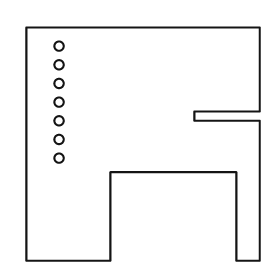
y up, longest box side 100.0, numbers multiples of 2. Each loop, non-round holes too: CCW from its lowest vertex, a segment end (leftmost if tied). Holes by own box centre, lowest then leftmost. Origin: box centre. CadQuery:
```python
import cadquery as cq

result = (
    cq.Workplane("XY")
    .moveTo(-50.0, -50.0)
    .lineTo(-14.0, -50.0)
    .lineTo(-14.0, -12.0)
    .lineTo(40.0, -12.0)
    .lineTo(40.0, -50.0)
    .lineTo(50.0, -50.0)
    .lineTo(50.0, 10.0)
    .lineTo(22.0, 10.0)
    .lineTo(22.0, 14.0)
    .lineTo(50.0, 14.0)
    .lineTo(50.0, 50.0)
    .lineTo(-50.0, 50.0)
    .close()
    .moveTo(-36.0, -6.0)
    .circle(2.0)
    .moveTo(-36.0, 2.0)
    .circle(2.0)
    .moveTo(-36.0, 10.0)
    .circle(2.0)
    .moveTo(-36.0, 18.0)
    .circle(2.0)
    .moveTo(-36.0, 26.0)
    .circle(2.0)
    .moveTo(-36.0, 34.0)
    .circle(2.0)
    .moveTo(-36.0, 42.0)
    .circle(2.0)
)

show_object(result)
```